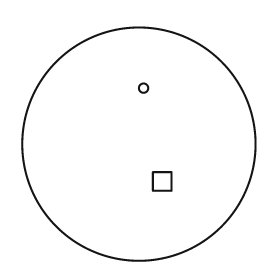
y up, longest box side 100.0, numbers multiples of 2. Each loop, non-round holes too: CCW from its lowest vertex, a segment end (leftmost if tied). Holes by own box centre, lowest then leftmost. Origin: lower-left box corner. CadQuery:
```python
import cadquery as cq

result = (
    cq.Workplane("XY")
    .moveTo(50.0, 50.0)
    .circle(50.0)
    .moveTo(56.0, 30.0)
    .lineTo(64.0, 30.0)
    .lineTo(64.0, 38.0)
    .lineTo(56.0, 38.0)
    .close()
    .moveTo(52.0, 74.0)
    .circle(2.0)
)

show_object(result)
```